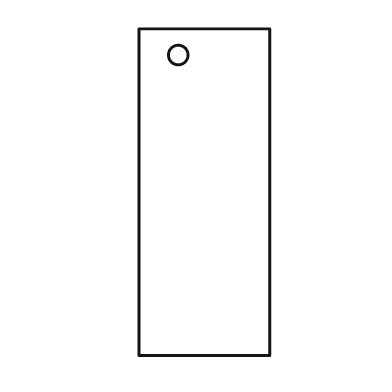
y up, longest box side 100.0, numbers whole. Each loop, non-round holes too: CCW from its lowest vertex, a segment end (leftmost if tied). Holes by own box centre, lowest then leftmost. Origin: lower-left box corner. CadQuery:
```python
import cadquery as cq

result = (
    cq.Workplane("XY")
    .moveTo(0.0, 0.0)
    .lineTo(40.0, 0.0)
    .lineTo(40.0, 100.0)
    .lineTo(0.0, 100.0)
    .close()
    .moveTo(12.0, 92.0)
    .circle(3.0)
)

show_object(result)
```